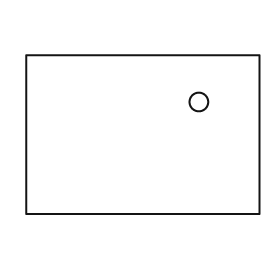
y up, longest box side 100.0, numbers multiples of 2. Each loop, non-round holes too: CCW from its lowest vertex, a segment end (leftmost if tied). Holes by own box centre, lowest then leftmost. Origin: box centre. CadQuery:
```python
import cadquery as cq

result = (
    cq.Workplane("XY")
    .moveTo(-50.0, -34.0)
    .lineTo(50.0, -34.0)
    .lineTo(50.0, 34.0)
    .lineTo(-50.0, 34.0)
    .close()
    .moveTo(24.0, 14.0)
    .circle(4.0)
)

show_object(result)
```